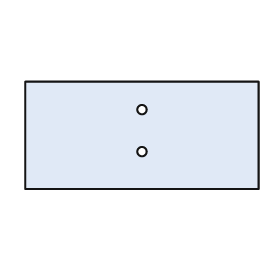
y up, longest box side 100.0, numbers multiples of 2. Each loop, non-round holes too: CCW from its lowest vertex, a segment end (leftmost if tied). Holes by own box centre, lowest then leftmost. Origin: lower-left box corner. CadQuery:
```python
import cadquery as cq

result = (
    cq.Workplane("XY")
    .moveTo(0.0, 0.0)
    .lineTo(100.0, 0.0)
    .lineTo(100.0, 46.0)
    .lineTo(0.0, 46.0)
    .close()
    .moveTo(50.0, 16.0)
    .circle(2.0)
    .moveTo(50.0, 34.0)
    .circle(2.0)
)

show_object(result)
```